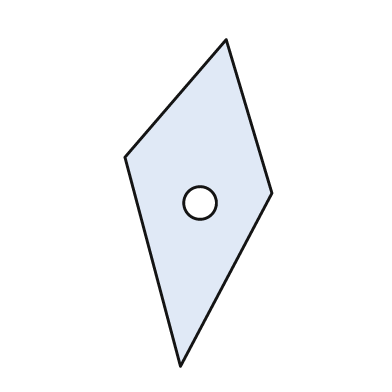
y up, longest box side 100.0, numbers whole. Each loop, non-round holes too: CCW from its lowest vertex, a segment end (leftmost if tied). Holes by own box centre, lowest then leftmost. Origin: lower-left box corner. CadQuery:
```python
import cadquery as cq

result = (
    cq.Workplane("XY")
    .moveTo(17.0, 0.0)
    .lineTo(45.0, 53.0)
    .lineTo(31.0, 100.0)
    .lineTo(0.0, 64.0)
    .close()
    .moveTo(23.0, 50.0)
    .circle(5.0)
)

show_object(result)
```